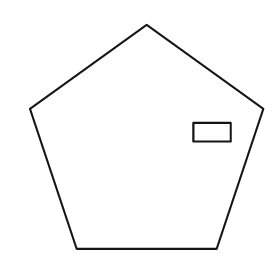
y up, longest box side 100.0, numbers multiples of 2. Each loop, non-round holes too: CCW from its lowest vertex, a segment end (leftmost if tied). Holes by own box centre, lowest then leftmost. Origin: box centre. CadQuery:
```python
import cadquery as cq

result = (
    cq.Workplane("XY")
    .moveTo(-30.0, -48.0)
    .lineTo(30.0, -48.0)
    .lineTo(50.0, 12.0)
    .lineTo(0.0, 48.0)
    .lineTo(-50.0, 12.0)
    .close()
    .moveTo(20.0, -2.0)
    .lineTo(36.0, -2.0)
    .lineTo(36.0, 6.0)
    .lineTo(20.0, 6.0)
    .close()
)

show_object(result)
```